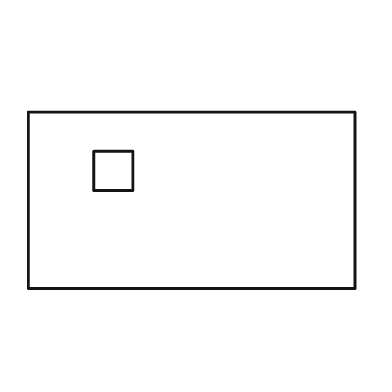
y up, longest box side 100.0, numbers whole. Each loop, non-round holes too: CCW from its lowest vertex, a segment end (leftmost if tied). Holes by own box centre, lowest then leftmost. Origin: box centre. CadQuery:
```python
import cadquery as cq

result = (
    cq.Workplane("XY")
    .moveTo(-50.0, -27.0)
    .lineTo(50.0, -27.0)
    .lineTo(50.0, 27.0)
    .lineTo(-50.0, 27.0)
    .close()
    .moveTo(-30.0, 3.0)
    .lineTo(-18.0, 3.0)
    .lineTo(-18.0, 15.0)
    .lineTo(-30.0, 15.0)
    .close()
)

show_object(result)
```